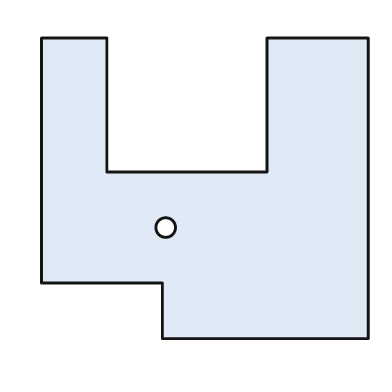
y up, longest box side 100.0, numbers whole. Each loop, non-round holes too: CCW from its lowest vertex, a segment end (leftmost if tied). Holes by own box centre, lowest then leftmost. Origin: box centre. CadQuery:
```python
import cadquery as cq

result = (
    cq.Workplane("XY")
    .moveTo(-13.0, -46.0)
    .lineTo(50.0, -46.0)
    .lineTo(50.0, 46.0)
    .lineTo(19.0, 46.0)
    .lineTo(19.0, 5.0)
    .lineTo(-30.0, 5.0)
    .lineTo(-30.0, 46.0)
    .lineTo(-50.0, 46.0)
    .lineTo(-50.0, -29.0)
    .lineTo(-13.0, -29.0)
    .close()
    .moveTo(-12.0, -12.0)
    .circle(3.0)
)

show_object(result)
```